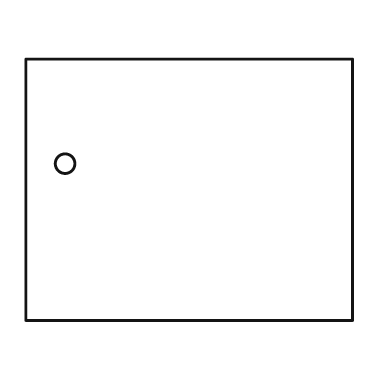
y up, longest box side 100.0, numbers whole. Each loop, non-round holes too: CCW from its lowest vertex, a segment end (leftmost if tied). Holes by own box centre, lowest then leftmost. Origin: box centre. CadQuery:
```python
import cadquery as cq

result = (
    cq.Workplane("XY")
    .moveTo(-50.0, -40.0)
    .lineTo(50.0, -40.0)
    .lineTo(50.0, 40.0)
    .lineTo(-50.0, 40.0)
    .close()
    .moveTo(-38.0, 8.0)
    .circle(3.0)
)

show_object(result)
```